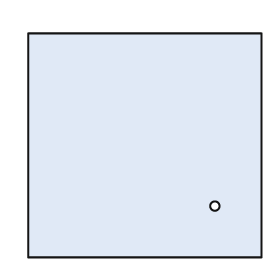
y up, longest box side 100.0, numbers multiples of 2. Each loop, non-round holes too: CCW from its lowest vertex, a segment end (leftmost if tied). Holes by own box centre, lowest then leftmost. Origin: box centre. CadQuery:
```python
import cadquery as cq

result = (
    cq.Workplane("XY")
    .moveTo(-50.0, -48.0)
    .lineTo(50.0, -48.0)
    .lineTo(50.0, 48.0)
    .lineTo(-50.0, 48.0)
    .close()
    .moveTo(30.0, -26.0)
    .circle(2.0)
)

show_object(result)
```